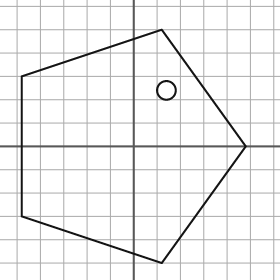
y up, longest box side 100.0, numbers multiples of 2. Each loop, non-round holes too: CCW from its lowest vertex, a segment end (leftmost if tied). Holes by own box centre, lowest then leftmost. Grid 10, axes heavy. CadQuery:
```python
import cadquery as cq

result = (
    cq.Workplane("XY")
    .moveTo(12.0, -50.0)
    .lineTo(48.0, 0.0)
    .lineTo(12.0, 50.0)
    .lineTo(-48.0, 30.0)
    .lineTo(-48.0, -30.0)
    .close()
    .moveTo(14.0, 24.0)
    .circle(4.0)
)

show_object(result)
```